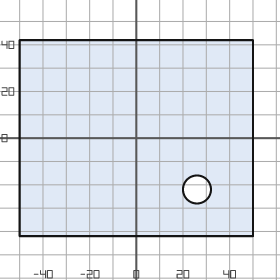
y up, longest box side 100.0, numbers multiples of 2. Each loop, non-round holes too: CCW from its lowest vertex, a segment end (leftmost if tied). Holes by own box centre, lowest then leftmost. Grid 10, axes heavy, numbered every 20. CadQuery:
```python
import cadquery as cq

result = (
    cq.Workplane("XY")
    .moveTo(-50.0, -42.0)
    .lineTo(50.0, -42.0)
    .lineTo(50.0, 42.0)
    .lineTo(-50.0, 42.0)
    .close()
    .moveTo(26.0, -22.0)
    .circle(6.0)
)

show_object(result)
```